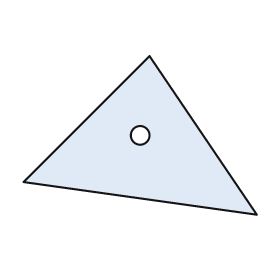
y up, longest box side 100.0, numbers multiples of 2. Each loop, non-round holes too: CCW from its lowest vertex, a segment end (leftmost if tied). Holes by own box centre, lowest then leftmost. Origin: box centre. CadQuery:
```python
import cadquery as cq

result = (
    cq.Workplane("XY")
    .moveTo(50.0, -34.0)
    .lineTo(4.0, 34.0)
    .lineTo(-50.0, -20.0)
    .close()
    .moveTo(0.0, 0.0)
    .circle(4.0)
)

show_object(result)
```